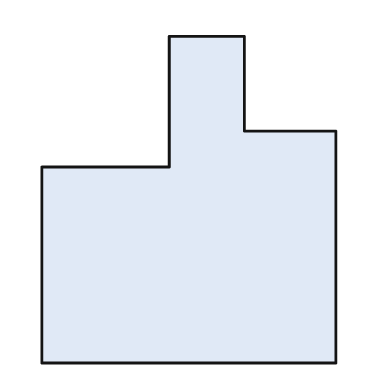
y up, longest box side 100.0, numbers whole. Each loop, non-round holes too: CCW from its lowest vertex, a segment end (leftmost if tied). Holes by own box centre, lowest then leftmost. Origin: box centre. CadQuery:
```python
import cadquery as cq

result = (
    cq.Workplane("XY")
    .moveTo(-45.0, -50.0)
    .lineTo(45.0, -50.0)
    .lineTo(45.0, 21.0)
    .lineTo(17.0, 21.0)
    .lineTo(17.0, 50.0)
    .lineTo(-6.0, 50.0)
    .lineTo(-6.0, 10.0)
    .lineTo(-45.0, 10.0)
    .close()
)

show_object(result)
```